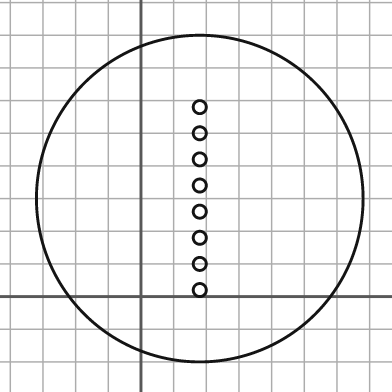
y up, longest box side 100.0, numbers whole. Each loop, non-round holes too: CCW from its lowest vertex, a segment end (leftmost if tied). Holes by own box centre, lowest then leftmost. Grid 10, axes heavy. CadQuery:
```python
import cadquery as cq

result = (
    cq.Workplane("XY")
    .moveTo(18.0, 30.0)
    .circle(50.0)
    .moveTo(18.0, 2.0)
    .circle(2.0)
    .moveTo(18.0, 10.0)
    .circle(2.0)
    .moveTo(18.0, 18.0)
    .circle(2.0)
    .moveTo(18.0, 26.0)
    .circle(2.0)
    .moveTo(18.0, 34.0)
    .circle(2.0)
    .moveTo(18.0, 42.0)
    .circle(2.0)
    .moveTo(18.0, 50.0)
    .circle(2.0)
    .moveTo(18.0, 58.0)
    .circle(2.0)
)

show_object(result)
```